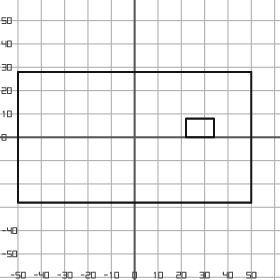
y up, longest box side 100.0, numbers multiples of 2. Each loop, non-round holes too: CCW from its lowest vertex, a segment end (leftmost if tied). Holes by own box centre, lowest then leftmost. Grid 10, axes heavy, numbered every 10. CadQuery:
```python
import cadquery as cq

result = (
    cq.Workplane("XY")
    .moveTo(-50.0, -28.0)
    .lineTo(50.0, -28.0)
    .lineTo(50.0, 28.0)
    .lineTo(-50.0, 28.0)
    .close()
    .moveTo(22.0, 0.0)
    .lineTo(34.0, 0.0)
    .lineTo(34.0, 8.0)
    .lineTo(22.0, 8.0)
    .close()
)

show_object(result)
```